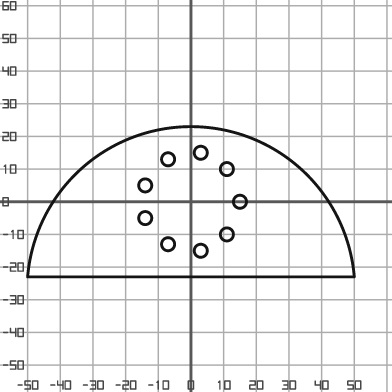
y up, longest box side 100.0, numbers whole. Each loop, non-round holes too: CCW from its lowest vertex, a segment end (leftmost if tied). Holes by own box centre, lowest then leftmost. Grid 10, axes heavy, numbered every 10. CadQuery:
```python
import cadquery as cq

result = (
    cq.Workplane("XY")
    .moveTo(-50.0, -23.0)
    .lineTo(50.0, -23.0)
    .threePointArc((0.0, 23.0), (-50.0, -23.0))
    .close()
    .moveTo(3.0, -15.0)
    .circle(2.0)
    .moveTo(-7.0, -13.0)
    .circle(2.0)
    .moveTo(11.0, -10.0)
    .circle(2.0)
    .moveTo(-14.0, -5.0)
    .circle(2.0)
    .moveTo(15.0, 0.0)
    .circle(2.0)
    .moveTo(-14.0, 5.0)
    .circle(2.0)
    .moveTo(11.0, 10.0)
    .circle(2.0)
    .moveTo(-7.0, 13.0)
    .circle(2.0)
    .moveTo(3.0, 15.0)
    .circle(2.0)
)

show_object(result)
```